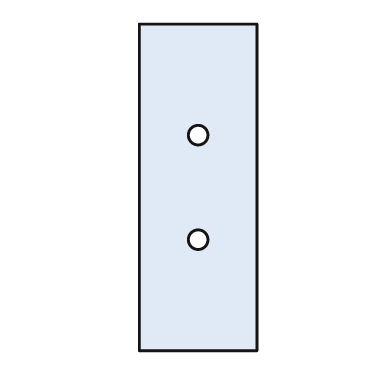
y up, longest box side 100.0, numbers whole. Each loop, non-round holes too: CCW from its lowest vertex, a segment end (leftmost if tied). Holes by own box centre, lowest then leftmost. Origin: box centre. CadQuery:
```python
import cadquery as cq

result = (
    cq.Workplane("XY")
    .moveTo(-18.0, -50.0)
    .lineTo(18.0, -50.0)
    .lineTo(18.0, 50.0)
    .lineTo(-18.0, 50.0)
    .close()
    .moveTo(0.0, -16.0)
    .circle(3.0)
    .moveTo(0.0, 16.0)
    .circle(3.0)
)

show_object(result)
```